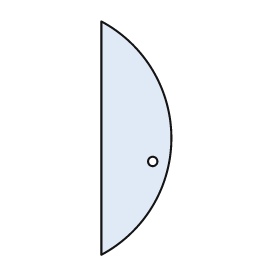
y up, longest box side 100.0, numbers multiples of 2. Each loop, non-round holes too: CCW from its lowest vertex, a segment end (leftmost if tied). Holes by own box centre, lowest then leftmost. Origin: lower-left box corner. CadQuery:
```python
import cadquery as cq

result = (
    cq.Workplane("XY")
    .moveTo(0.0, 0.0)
    .threePointArc((30.0, 50.0), (0.0, 100.0))
    .close()
    .moveTo(22.0, 40.0)
    .circle(2.0)
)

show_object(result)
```